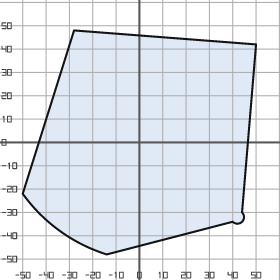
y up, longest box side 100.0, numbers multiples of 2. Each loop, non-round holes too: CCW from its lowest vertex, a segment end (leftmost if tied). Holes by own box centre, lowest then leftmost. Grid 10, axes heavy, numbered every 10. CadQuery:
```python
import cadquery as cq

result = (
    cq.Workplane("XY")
    .moveTo(-14.0, -48.0)
    .lineTo(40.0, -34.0)
    .threePointArc((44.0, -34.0), (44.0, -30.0))
    .lineTo(50.0, 42.0)
    .lineTo(-28.0, 48.0)
    .lineTo(-50.0, -22.0)
    .threePointArc((-34.0, -38.0), (-14.0, -48.0))
    .close()
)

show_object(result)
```